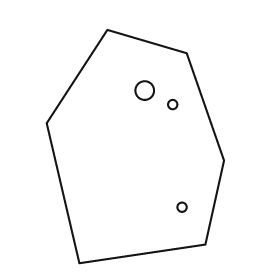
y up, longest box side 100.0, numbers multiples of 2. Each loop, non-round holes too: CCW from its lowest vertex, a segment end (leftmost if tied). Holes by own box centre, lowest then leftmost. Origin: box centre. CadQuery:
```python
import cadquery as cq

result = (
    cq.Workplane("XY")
    .moveTo(-24.0, -50.0)
    .lineTo(30.0, -42.0)
    .lineTo(38.0, -6.0)
    .lineTo(22.0, 40.0)
    .lineTo(-12.0, 50.0)
    .lineTo(-38.0, 10.0)
    .close()
    .moveTo(20.0, -26.0)
    .circle(2.0)
    .moveTo(16.0, 18.0)
    .circle(2.0)
    .moveTo(4.0, 24.0)
    .circle(4.0)
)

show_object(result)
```